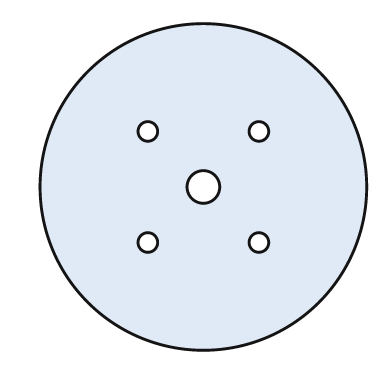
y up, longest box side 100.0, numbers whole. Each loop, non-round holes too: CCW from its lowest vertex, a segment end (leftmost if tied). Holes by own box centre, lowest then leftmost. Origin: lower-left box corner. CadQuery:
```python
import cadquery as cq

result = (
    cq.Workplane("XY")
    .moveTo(50.0, 50.0)
    .circle(50.0)
    .moveTo(33.0, 33.0)
    .circle(3.0)
    .moveTo(67.0, 33.0)
    .circle(3.0)
    .moveTo(50.0, 50.0)
    .circle(5.0)
    .moveTo(33.0, 67.0)
    .circle(3.0)
    .moveTo(67.0, 67.0)
    .circle(3.0)
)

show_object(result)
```